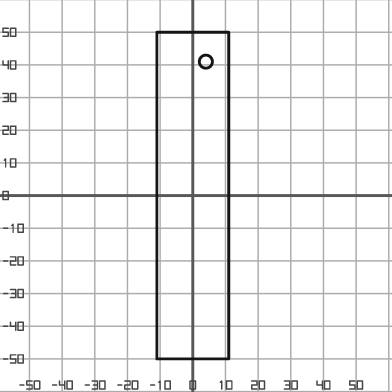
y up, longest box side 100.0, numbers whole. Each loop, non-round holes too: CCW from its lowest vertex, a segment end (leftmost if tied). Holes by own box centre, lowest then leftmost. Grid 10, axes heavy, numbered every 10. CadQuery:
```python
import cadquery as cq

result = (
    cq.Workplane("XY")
    .moveTo(-11.0, -50.0)
    .lineTo(11.0, -50.0)
    .lineTo(11.0, 50.0)
    .lineTo(-11.0, 50.0)
    .close()
    .moveTo(4.0, 41.0)
    .circle(2.0)
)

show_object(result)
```